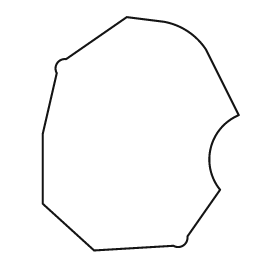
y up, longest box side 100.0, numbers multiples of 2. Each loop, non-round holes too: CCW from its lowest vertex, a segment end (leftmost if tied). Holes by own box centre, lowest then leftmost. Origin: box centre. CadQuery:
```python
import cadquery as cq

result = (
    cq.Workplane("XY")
    .moveTo(-20.0, -50.0)
    .lineTo(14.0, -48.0)
    .threePointArc((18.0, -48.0), (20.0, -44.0))
    .lineTo(34.0, -24.0)
    .threePointArc((30.0, -6.0), (42.0, 8.0))
    .lineTo(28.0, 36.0)
    .threePointArc((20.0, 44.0), (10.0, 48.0))
    .lineTo(-6.0, 50.0)
    .lineTo(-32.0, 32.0)
    .threePointArc((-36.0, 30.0), (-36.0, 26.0))
    .lineTo(-42.0, 0.0)
    .lineTo(-42.0, -30.0)
    .close()
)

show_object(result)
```